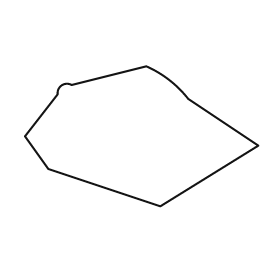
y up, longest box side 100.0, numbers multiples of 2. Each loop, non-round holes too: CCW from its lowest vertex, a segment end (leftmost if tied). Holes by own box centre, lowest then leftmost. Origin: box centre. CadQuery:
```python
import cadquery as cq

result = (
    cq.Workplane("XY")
    .moveTo(8.0, -30.0)
    .lineTo(50.0, -4.0)
    .lineTo(20.0, 16.0)
    .threePointArc((12.0, 24.0), (2.0, 30.0))
    .lineTo(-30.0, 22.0)
    .threePointArc((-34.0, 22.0), (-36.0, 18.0))
    .lineTo(-50.0, 0.0)
    .lineTo(-40.0, -14.0)
    .close()
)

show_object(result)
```